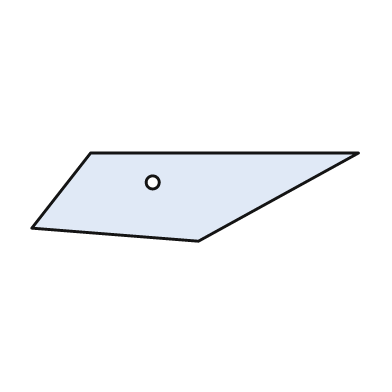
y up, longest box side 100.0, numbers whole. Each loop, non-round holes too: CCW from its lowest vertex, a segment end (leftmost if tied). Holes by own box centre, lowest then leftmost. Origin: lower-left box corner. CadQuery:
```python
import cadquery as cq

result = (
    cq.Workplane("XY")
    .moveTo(51.0, 0.0)
    .lineTo(100.0, 27.0)
    .lineTo(18.0, 27.0)
    .lineTo(0.0, 4.0)
    .close()
    .moveTo(37.0, 18.0)
    .circle(2.0)
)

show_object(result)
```